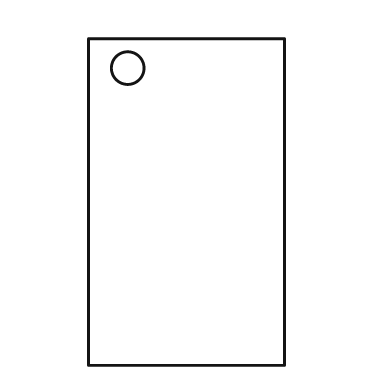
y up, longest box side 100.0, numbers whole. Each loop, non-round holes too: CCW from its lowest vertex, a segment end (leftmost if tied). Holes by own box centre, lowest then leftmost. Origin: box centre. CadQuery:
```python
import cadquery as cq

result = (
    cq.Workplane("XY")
    .moveTo(-30.0, -50.0)
    .lineTo(30.0, -50.0)
    .lineTo(30.0, 50.0)
    .lineTo(-30.0, 50.0)
    .close()
    .moveTo(-18.0, 41.0)
    .circle(5.0)
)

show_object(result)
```